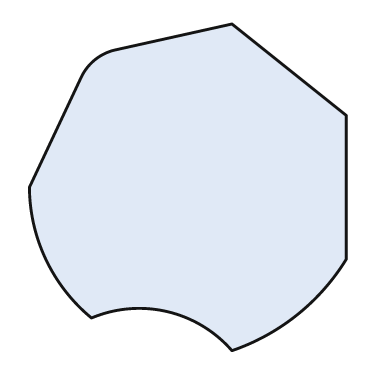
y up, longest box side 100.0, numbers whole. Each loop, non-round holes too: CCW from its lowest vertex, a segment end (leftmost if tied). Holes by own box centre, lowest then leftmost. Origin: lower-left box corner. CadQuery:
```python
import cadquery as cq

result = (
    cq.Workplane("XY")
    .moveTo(62.0, 0.0)
    .threePointArc((82.0, 11.0), (97.0, 28.0))
    .lineTo(97.0, 72.0)
    .lineTo(62.0, 100.0)
    .lineTo(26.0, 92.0)
    .threePointArc((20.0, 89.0), (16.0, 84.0))
    .lineTo(0.0, 50.0)
    .threePointArc((5.0, 28.0), (19.0, 10.0))
    .threePointArc((42.0, 12.0), (62.0, 0.0))
    .close()
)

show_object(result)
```